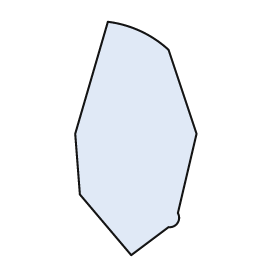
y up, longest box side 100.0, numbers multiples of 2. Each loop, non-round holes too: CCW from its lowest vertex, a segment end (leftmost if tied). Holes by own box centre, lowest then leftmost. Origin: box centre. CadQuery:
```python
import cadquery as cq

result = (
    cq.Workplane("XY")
    .moveTo(-2.0, -50.0)
    .lineTo(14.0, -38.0)
    .threePointArc((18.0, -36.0), (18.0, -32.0))
    .lineTo(26.0, 2.0)
    .lineTo(14.0, 38.0)
    .threePointArc((2.0, 46.0), (-12.0, 50.0))
    .lineTo(-26.0, 2.0)
    .lineTo(-24.0, -24.0)
    .close()
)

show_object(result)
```